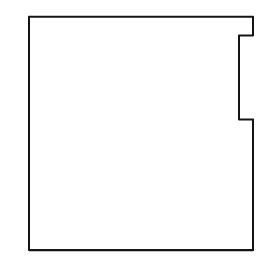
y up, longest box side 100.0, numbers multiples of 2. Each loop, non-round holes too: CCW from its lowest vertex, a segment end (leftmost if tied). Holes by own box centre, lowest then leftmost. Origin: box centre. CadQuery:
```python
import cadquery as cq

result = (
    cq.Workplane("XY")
    .moveTo(-48.0, -50.0)
    .lineTo(48.0, -50.0)
    .lineTo(48.0, 6.0)
    .lineTo(42.0, 6.0)
    .lineTo(42.0, 42.0)
    .lineTo(48.0, 42.0)
    .lineTo(48.0, 50.0)
    .lineTo(-48.0, 50.0)
    .close()
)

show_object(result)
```